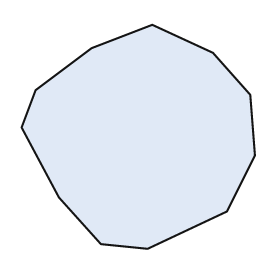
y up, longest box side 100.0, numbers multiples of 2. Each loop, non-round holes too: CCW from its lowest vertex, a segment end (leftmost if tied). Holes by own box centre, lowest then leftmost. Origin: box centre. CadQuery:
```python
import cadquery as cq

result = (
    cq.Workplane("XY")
    .moveTo(4.0, -48.0)
    .lineTo(38.0, -32.0)
    .lineTo(50.0, -8.0)
    .lineTo(48.0, 18.0)
    .lineTo(32.0, 36.0)
    .lineTo(6.0, 48.0)
    .lineTo(-20.0, 38.0)
    .lineTo(-44.0, 20.0)
    .lineTo(-50.0, 4.0)
    .lineTo(-34.0, -26.0)
    .lineTo(-16.0, -46.0)
    .close()
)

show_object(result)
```